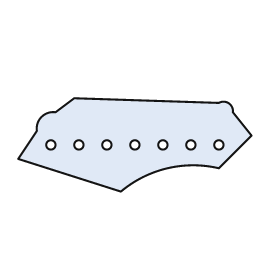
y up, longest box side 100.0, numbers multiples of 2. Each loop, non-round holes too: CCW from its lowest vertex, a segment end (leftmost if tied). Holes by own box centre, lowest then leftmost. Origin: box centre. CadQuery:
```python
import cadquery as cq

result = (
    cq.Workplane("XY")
    .moveTo(-6.0, -20.0)
    .threePointArc((14.0, -10.0), (36.0, -10.0))
    .lineTo(50.0, 4.0)
    .lineTo(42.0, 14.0)
    .threePointArc((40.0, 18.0), (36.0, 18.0))
    .lineTo(-26.0, 20.0)
    .lineTo(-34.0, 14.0)
    .threePointArc((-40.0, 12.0), (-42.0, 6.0))
    .lineTo(-50.0, -6.0)
    .close()
    .moveTo(-36.0, 0.0)
    .circle(2.0)
    .moveTo(-24.0, 0.0)
    .circle(2.0)
    .moveTo(-12.0, 0.0)
    .circle(2.0)
    .moveTo(0.0, 0.0)
    .circle(2.0)
    .moveTo(12.0, 0.0)
    .circle(2.0)
    .moveTo(24.0, 0.0)
    .circle(2.0)
    .moveTo(36.0, 0.0)
    .circle(2.0)
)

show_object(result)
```